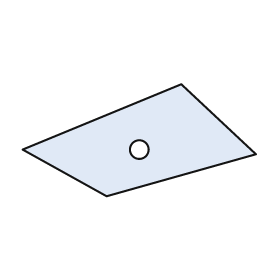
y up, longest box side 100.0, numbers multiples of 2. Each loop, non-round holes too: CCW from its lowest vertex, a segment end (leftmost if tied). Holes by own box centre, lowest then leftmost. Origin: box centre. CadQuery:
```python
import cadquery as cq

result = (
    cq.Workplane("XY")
    .moveTo(-14.0, -24.0)
    .lineTo(50.0, -6.0)
    .lineTo(18.0, 24.0)
    .lineTo(-50.0, -4.0)
    .close()
    .moveTo(0.0, -4.0)
    .circle(4.0)
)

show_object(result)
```